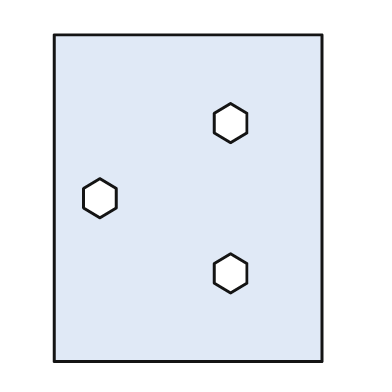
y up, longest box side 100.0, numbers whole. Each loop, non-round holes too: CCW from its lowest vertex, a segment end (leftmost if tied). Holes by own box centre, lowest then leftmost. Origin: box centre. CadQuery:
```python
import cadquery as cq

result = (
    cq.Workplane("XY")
    .moveTo(-41.0, -50.0)
    .lineTo(41.0, -50.0)
    .lineTo(41.0, 50.0)
    .lineTo(-41.0, 50.0)
    .close()
    .moveTo(13.0, -29.0)
    .lineTo(18.0, -26.0)
    .lineTo(18.0, -20.0)
    .lineTo(13.0, -17.0)
    .lineTo(8.0, -20.0)
    .lineTo(8.0, -26.0)
    .close()
    .moveTo(-27.0, -6.0)
    .lineTo(-22.0, -3.0)
    .lineTo(-22.0, 3.0)
    .lineTo(-27.0, 6.0)
    .lineTo(-32.0, 3.0)
    .lineTo(-32.0, -3.0)
    .close()
    .moveTo(13.0, 17.0)
    .lineTo(18.0, 20.0)
    .lineTo(18.0, 26.0)
    .lineTo(13.0, 29.0)
    .lineTo(8.0, 26.0)
    .lineTo(8.0, 20.0)
    .close()
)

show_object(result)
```